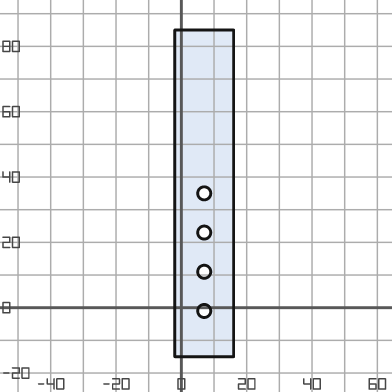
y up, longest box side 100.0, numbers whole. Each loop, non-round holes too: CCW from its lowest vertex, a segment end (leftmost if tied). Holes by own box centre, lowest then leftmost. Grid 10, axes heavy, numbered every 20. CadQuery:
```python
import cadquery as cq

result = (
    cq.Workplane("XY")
    .moveTo(-2.0, -15.0)
    .lineTo(16.0, -15.0)
    .lineTo(16.0, 85.0)
    .lineTo(-2.0, 85.0)
    .close()
    .moveTo(7.0, -1.0)
    .circle(2.0)
    .moveTo(7.0, 11.0)
    .circle(2.0)
    .moveTo(7.0, 23.0)
    .circle(2.0)
    .moveTo(7.0, 35.0)
    .circle(2.0)
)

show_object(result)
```